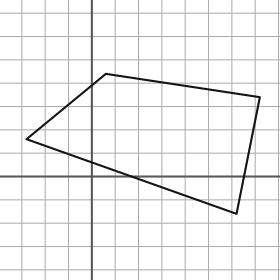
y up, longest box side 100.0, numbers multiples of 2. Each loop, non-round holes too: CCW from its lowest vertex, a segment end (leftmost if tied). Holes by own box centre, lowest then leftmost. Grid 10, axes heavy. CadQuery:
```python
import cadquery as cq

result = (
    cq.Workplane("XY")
    .moveTo(62.0, -16.0)
    .lineTo(72.0, 34.0)
    .lineTo(6.0, 44.0)
    .lineTo(-28.0, 16.0)
    .close()
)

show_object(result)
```